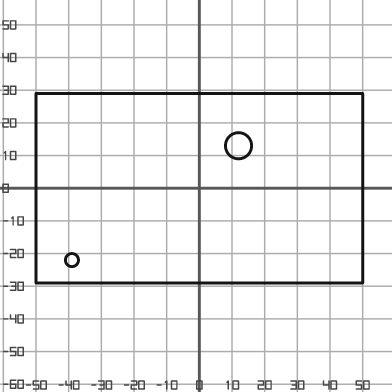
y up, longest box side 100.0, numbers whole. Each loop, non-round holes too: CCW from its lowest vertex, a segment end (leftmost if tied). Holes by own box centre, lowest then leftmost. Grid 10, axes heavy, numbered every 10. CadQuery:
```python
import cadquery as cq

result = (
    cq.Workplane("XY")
    .moveTo(-50.0, -29.0)
    .lineTo(50.0, -29.0)
    .lineTo(50.0, 29.0)
    .lineTo(-50.0, 29.0)
    .close()
    .moveTo(-39.0, -22.0)
    .circle(2.0)
    .moveTo(12.0, 13.0)
    .circle(4.0)
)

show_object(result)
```